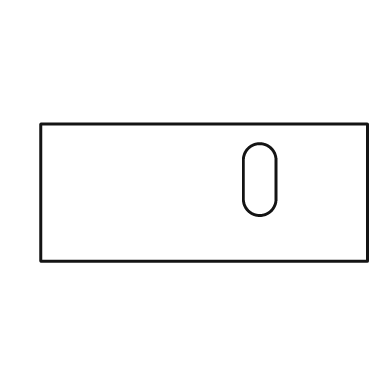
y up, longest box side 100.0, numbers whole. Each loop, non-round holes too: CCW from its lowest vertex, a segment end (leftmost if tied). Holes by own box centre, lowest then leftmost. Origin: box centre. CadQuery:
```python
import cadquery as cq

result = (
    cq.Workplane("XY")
    .moveTo(-50.0, -21.0)
    .lineTo(50.0, -21.0)
    .lineTo(50.0, 21.0)
    .lineTo(-50.0, 21.0)
    .close()
    .moveTo(12.0, -2.0)
    .threePointArc((17.0, -7.0), (22.0, -2.0))
    .lineTo(22.0, 10.0)
    .threePointArc((17.0, 15.0), (12.0, 10.0))
    .close()
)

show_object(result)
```